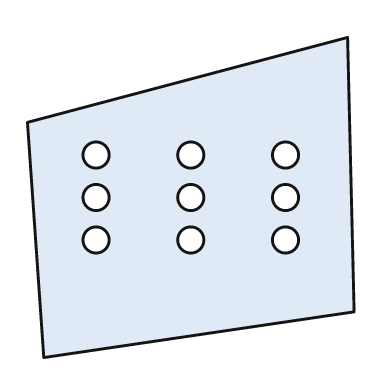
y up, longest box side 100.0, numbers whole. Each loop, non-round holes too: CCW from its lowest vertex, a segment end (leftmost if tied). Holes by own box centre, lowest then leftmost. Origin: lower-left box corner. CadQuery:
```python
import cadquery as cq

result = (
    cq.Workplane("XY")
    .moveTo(5.0, 0.0)
    .lineTo(100.0, 14.0)
    .lineTo(98.0, 98.0)
    .lineTo(0.0, 72.0)
    .close()
    .moveTo(21.0, 36.0)
    .circle(4.0)
    .moveTo(50.0, 36.0)
    .circle(4.0)
    .moveTo(79.0, 36.0)
    .circle(4.0)
    .moveTo(21.0, 49.0)
    .circle(4.0)
    .moveTo(50.0, 49.0)
    .circle(4.0)
    .moveTo(79.0, 49.0)
    .circle(4.0)
    .moveTo(21.0, 62.0)
    .circle(4.0)
    .moveTo(50.0, 62.0)
    .circle(4.0)
    .moveTo(79.0, 62.0)
    .circle(4.0)
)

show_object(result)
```